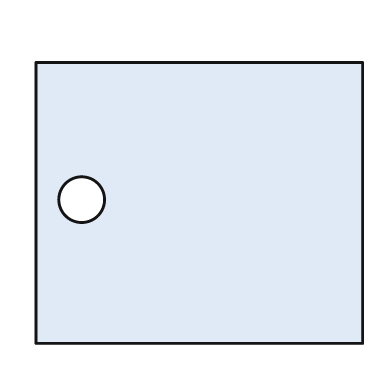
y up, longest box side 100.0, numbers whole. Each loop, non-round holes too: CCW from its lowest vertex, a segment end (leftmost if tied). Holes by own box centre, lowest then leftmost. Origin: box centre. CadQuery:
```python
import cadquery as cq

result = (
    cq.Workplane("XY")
    .moveTo(-50.0, -43.0)
    .lineTo(50.0, -43.0)
    .lineTo(50.0, 43.0)
    .lineTo(-50.0, 43.0)
    .close()
    .moveTo(-36.0, 1.0)
    .circle(7.0)
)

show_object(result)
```